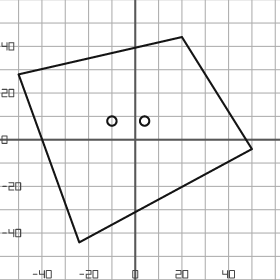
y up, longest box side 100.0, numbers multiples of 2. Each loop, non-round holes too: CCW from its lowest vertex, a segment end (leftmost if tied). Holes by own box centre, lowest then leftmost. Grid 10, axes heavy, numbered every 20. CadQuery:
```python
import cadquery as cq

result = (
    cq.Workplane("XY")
    .moveTo(-24.0, -44.0)
    .lineTo(50.0, -4.0)
    .lineTo(20.0, 44.0)
    .lineTo(-50.0, 28.0)
    .close()
    .moveTo(-10.0, 8.0)
    .circle(2.0)
    .moveTo(4.0, 8.0)
    .circle(2.0)
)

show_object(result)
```